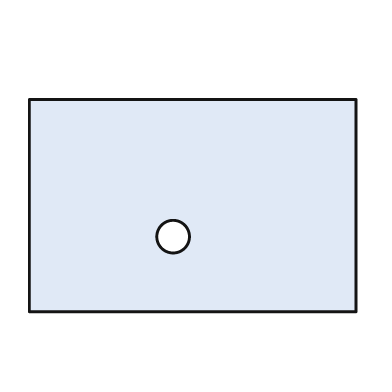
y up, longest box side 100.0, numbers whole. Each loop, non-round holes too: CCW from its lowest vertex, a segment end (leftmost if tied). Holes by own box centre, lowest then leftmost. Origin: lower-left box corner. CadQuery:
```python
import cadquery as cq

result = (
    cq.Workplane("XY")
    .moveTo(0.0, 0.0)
    .lineTo(100.0, 0.0)
    .lineTo(100.0, 65.0)
    .lineTo(0.0, 65.0)
    .close()
    .moveTo(44.0, 23.0)
    .circle(5.0)
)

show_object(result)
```